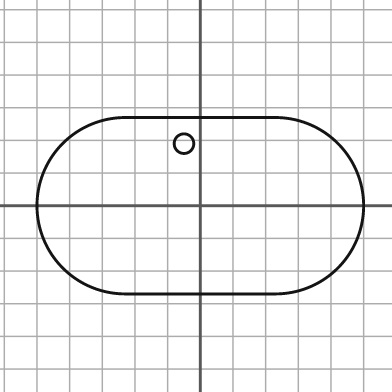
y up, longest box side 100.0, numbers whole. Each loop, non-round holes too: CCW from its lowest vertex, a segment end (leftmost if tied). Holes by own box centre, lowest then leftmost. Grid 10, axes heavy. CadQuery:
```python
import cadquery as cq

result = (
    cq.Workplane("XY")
    .moveTo(-23.0, -27.0)
    .lineTo(23.0, -27.0)
    .threePointArc((50.0, 0.0), (23.0, 27.0))
    .lineTo(-23.0, 27.0)
    .threePointArc((-50.0, 0.0), (-23.0, -27.0))
    .close()
    .moveTo(-5.0, 19.0)
    .circle(3.0)
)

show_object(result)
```